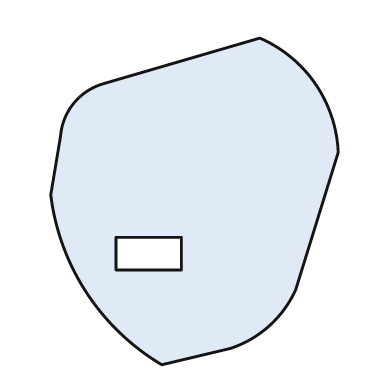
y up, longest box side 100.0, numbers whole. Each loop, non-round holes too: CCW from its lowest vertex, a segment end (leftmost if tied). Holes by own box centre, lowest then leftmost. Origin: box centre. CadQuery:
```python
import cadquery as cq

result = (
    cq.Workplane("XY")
    .moveTo(-10.0, -50.0)
    .lineTo(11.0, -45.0)
    .threePointArc((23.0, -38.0), (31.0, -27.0))
    .lineTo(44.0, 15.0)
    .threePointArc((37.0, 36.0), (20.0, 50.0))
    .lineTo(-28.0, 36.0)
    .threePointArc((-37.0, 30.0), (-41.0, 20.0))
    .lineTo(-44.0, 2.0)
    .threePointArc((-33.0, -28.0), (-10.0, -50.0))
    .close()
    .moveTo(-24.0, -21.0)
    .lineTo(-4.0, -21.0)
    .lineTo(-4.0, -11.0)
    .lineTo(-24.0, -11.0)
    .close()
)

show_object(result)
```